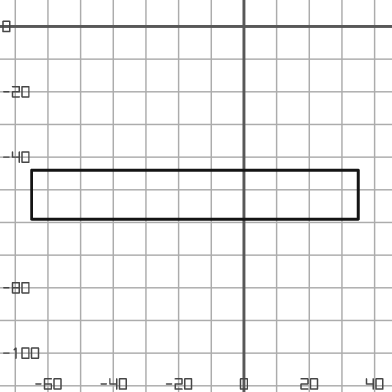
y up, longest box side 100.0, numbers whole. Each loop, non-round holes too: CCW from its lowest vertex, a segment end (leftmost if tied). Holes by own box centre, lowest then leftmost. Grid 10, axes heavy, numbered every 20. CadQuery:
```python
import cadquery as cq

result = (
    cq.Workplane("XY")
    .moveTo(-65.0, -59.0)
    .lineTo(35.0, -59.0)
    .lineTo(35.0, -44.0)
    .lineTo(-65.0, -44.0)
    .close()
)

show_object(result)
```